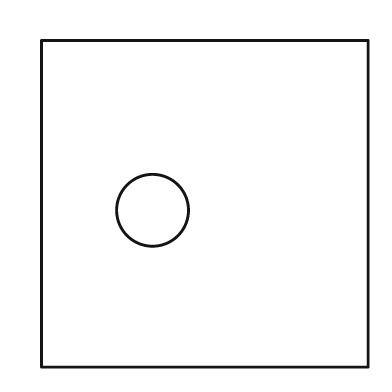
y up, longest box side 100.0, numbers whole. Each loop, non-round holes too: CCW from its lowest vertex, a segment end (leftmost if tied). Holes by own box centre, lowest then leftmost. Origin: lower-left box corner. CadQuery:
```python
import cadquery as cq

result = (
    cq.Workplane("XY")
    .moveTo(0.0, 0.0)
    .lineTo(100.0, 0.0)
    .lineTo(100.0, 100.0)
    .lineTo(0.0, 100.0)
    .close()
    .moveTo(34.0, 48.0)
    .circle(11.0)
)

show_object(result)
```